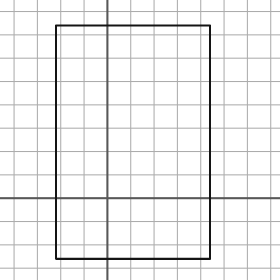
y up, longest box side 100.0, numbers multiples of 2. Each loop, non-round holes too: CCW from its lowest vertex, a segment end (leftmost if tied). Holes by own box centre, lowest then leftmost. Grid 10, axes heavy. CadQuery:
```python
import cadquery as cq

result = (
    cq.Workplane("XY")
    .moveTo(-22.0, -26.0)
    .lineTo(44.0, -26.0)
    .lineTo(44.0, 74.0)
    .lineTo(-22.0, 74.0)
    .close()
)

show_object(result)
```